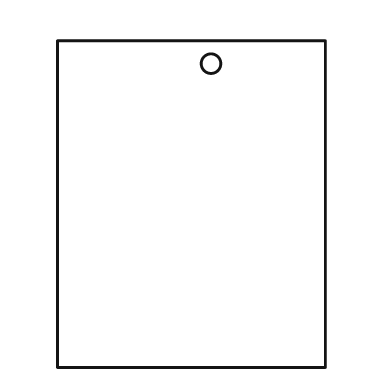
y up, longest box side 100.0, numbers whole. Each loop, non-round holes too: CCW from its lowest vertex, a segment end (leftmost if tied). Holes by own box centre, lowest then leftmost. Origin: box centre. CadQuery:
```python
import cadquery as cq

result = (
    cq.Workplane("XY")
    .moveTo(-41.0, -50.0)
    .lineTo(41.0, -50.0)
    .lineTo(41.0, 50.0)
    .lineTo(-41.0, 50.0)
    .close()
    .moveTo(6.0, 43.0)
    .circle(3.0)
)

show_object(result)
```